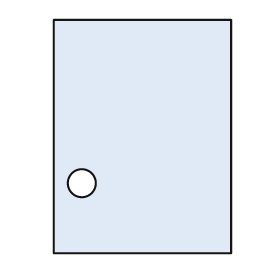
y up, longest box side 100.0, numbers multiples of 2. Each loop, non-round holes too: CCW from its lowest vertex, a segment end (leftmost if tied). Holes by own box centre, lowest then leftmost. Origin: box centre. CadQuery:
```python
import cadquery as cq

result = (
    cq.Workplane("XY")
    .moveTo(-38.0, -50.0)
    .lineTo(38.0, -50.0)
    .lineTo(38.0, 50.0)
    .lineTo(-38.0, 50.0)
    .close()
    .moveTo(-26.0, -20.0)
    .circle(6.0)
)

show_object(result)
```